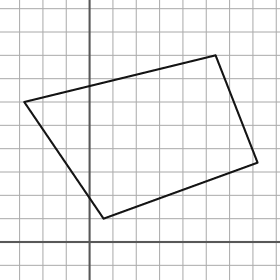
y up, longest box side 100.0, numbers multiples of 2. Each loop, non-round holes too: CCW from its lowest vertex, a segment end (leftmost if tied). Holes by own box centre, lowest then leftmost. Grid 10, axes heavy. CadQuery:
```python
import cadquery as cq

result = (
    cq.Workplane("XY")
    .moveTo(6.0, 10.0)
    .lineTo(72.0, 34.0)
    .lineTo(54.0, 80.0)
    .lineTo(-28.0, 60.0)
    .close()
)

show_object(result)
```